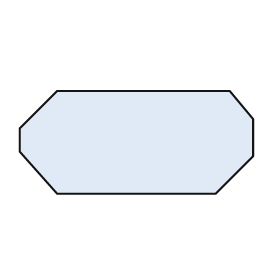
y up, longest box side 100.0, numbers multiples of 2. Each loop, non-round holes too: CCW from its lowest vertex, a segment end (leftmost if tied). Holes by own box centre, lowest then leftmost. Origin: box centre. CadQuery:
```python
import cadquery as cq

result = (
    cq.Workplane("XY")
    .moveTo(-34.0, -22.0)
    .lineTo(34.0, -22.0)
    .lineTo(50.0, -6.0)
    .lineTo(50.0, 10.0)
    .lineTo(40.0, 22.0)
    .lineTo(-34.0, 22.0)
    .lineTo(-50.0, 6.0)
    .lineTo(-50.0, -4.0)
    .close()
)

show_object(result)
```